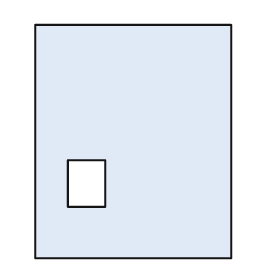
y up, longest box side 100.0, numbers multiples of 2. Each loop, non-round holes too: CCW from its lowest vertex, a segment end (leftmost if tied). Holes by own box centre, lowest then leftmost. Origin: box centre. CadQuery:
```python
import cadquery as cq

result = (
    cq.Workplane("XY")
    .moveTo(-42.0, -50.0)
    .lineTo(42.0, -50.0)
    .lineTo(42.0, 50.0)
    .lineTo(-42.0, 50.0)
    .close()
    .moveTo(-28.0, -28.0)
    .lineTo(-12.0, -28.0)
    .lineTo(-12.0, -8.0)
    .lineTo(-28.0, -8.0)
    .close()
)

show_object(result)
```